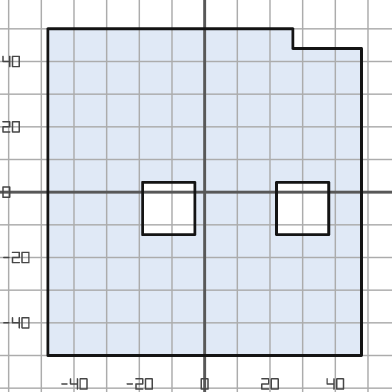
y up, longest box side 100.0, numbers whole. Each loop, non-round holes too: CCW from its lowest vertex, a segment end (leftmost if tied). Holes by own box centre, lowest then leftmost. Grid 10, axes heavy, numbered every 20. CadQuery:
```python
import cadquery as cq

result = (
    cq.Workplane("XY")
    .moveTo(-48.0, -50.0)
    .lineTo(48.0, -50.0)
    .lineTo(48.0, 44.0)
    .lineTo(27.0, 44.0)
    .lineTo(27.0, 50.0)
    .lineTo(-48.0, 50.0)
    .close()
    .moveTo(-19.0, -13.0)
    .lineTo(-3.0, -13.0)
    .lineTo(-3.0, 3.0)
    .lineTo(-19.0, 3.0)
    .close()
    .moveTo(22.0, -13.0)
    .lineTo(38.0, -13.0)
    .lineTo(38.0, 3.0)
    .lineTo(22.0, 3.0)
    .close()
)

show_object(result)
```